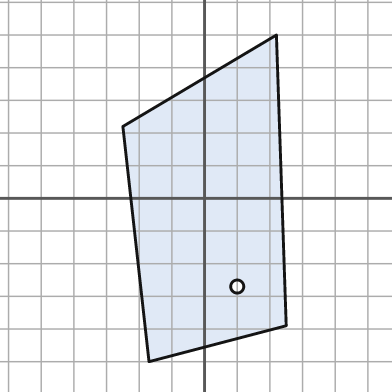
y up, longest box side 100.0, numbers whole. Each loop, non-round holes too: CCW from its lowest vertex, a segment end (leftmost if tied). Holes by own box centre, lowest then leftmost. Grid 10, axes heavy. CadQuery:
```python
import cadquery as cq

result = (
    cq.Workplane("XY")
    .moveTo(-17.0, -50.0)
    .lineTo(25.0, -39.0)
    .lineTo(22.0, 50.0)
    .lineTo(-25.0, 22.0)
    .close()
    .moveTo(10.0, -27.0)
    .circle(2.0)
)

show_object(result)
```